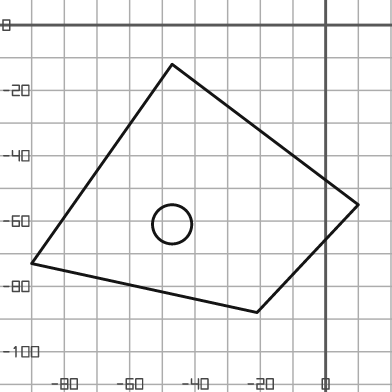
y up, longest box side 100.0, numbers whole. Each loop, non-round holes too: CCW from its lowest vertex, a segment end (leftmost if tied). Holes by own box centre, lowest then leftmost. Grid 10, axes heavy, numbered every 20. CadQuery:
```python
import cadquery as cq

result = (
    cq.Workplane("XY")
    .moveTo(-21.0, -88.0)
    .lineTo(10.0, -55.0)
    .lineTo(-47.0, -12.0)
    .lineTo(-90.0, -73.0)
    .close()
    .moveTo(-47.0, -61.0)
    .circle(6.0)
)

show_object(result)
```